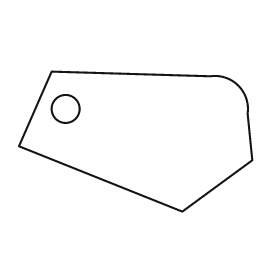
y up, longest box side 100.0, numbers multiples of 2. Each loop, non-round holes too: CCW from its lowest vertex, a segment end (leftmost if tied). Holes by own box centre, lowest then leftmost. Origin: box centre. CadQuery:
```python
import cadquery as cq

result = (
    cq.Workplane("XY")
    .moveTo(20.0, -30.0)
    .lineTo(50.0, -8.0)
    .lineTo(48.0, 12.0)
    .threePointArc((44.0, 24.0), (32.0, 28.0))
    .lineTo(-36.0, 30.0)
    .lineTo(-50.0, -2.0)
    .close()
    .moveTo(-30.0, 14.0)
    .circle(6.0)
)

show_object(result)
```